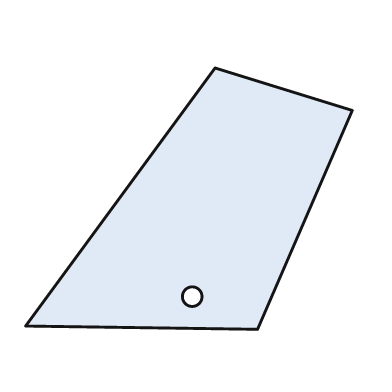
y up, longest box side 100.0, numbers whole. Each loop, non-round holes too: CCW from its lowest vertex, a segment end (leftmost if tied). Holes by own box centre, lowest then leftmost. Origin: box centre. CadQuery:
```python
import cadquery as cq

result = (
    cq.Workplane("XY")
    .moveTo(21.0, -40.0)
    .lineTo(50.0, 27.0)
    .lineTo(8.0, 40.0)
    .lineTo(-50.0, -39.0)
    .close()
    .moveTo(1.0, -30.0)
    .circle(3.0)
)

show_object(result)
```